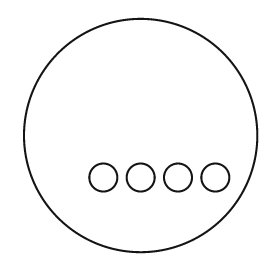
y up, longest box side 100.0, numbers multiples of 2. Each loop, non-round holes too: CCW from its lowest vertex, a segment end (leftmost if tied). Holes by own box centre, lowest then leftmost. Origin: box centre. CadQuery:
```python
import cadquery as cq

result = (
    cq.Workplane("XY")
    .moveTo(0.0, 0.0)
    .circle(50.0)
    .moveTo(-16.0, -18.0)
    .circle(6.0)
    .moveTo(0.0, -18.0)
    .circle(6.0)
    .moveTo(16.0, -18.0)
    .circle(6.0)
    .moveTo(32.0, -18.0)
    .circle(6.0)
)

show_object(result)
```